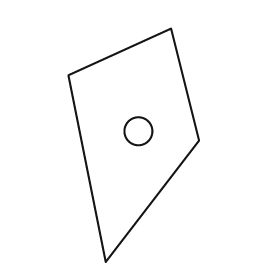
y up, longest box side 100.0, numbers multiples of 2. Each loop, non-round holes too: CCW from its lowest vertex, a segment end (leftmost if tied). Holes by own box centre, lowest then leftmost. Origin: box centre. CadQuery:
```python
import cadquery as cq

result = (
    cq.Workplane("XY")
    .moveTo(-12.0, -50.0)
    .lineTo(28.0, 2.0)
    .lineTo(16.0, 50.0)
    .lineTo(-28.0, 30.0)
    .close()
    .moveTo(2.0, 6.0)
    .circle(6.0)
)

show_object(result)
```